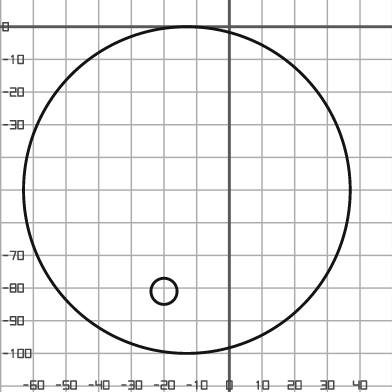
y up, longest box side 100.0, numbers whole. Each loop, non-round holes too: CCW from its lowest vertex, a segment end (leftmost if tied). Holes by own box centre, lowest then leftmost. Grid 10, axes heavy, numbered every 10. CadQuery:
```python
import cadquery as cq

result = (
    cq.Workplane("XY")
    .moveTo(-13.0, -50.0)
    .circle(50.0)
    .moveTo(-20.0, -81.0)
    .circle(4.0)
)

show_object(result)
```